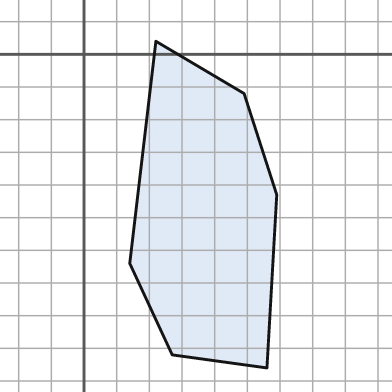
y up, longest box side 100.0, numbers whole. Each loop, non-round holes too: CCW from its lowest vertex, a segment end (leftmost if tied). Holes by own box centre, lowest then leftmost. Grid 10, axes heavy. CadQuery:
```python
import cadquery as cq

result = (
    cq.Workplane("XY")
    .moveTo(56.0, -96.0)
    .lineTo(59.0, -43.0)
    .lineTo(49.0, -12.0)
    .lineTo(22.0, 4.0)
    .lineTo(14.0, -64.0)
    .lineTo(27.0, -92.0)
    .close()
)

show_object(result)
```